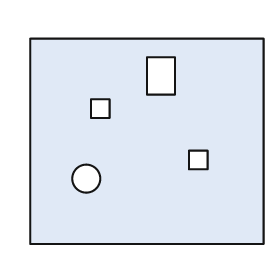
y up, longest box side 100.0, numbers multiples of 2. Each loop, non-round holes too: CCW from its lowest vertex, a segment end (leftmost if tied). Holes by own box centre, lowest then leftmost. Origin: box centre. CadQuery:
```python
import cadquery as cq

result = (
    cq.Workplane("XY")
    .moveTo(-50.0, -44.0)
    .lineTo(50.0, -44.0)
    .lineTo(50.0, 44.0)
    .lineTo(-50.0, 44.0)
    .close()
    .moveTo(-26.0, -16.0)
    .circle(6.0)
    .moveTo(18.0, -12.0)
    .lineTo(26.0, -12.0)
    .lineTo(26.0, -4.0)
    .lineTo(18.0, -4.0)
    .close()
    .moveTo(-24.0, 10.0)
    .lineTo(-16.0, 10.0)
    .lineTo(-16.0, 18.0)
    .lineTo(-24.0, 18.0)
    .close()
    .moveTo(0.0, 20.0)
    .lineTo(12.0, 20.0)
    .lineTo(12.0, 36.0)
    .lineTo(0.0, 36.0)
    .close()
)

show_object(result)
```